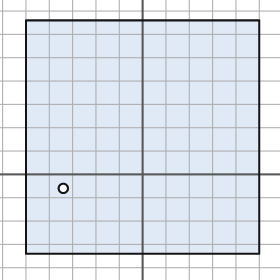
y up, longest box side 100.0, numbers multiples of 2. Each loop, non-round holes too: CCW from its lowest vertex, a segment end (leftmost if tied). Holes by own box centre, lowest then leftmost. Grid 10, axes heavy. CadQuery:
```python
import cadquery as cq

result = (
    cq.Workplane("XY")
    .moveTo(-50.0, -34.0)
    .lineTo(50.0, -34.0)
    .lineTo(50.0, 66.0)
    .lineTo(-50.0, 66.0)
    .close()
    .moveTo(-34.0, -6.0)
    .circle(2.0)
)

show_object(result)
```